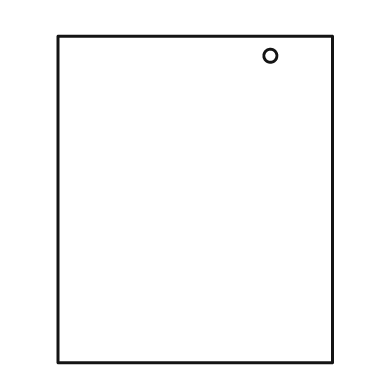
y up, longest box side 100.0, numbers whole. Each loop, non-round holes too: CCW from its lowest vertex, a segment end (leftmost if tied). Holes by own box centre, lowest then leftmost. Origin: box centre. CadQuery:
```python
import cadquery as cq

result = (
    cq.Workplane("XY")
    .moveTo(-42.0, -50.0)
    .lineTo(42.0, -50.0)
    .lineTo(42.0, 50.0)
    .lineTo(-42.0, 50.0)
    .close()
    .moveTo(23.0, 44.0)
    .circle(2.0)
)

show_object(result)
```